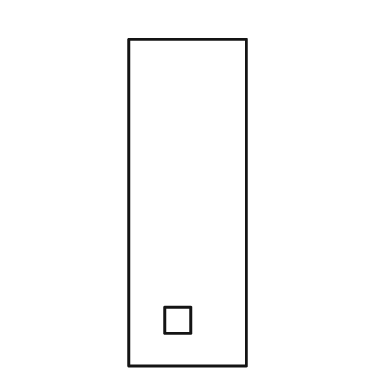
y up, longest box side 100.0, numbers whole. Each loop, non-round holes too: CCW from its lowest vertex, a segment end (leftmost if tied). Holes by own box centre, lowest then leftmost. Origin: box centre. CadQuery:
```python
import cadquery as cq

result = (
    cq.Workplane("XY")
    .moveTo(-18.0, -50.0)
    .lineTo(18.0, -50.0)
    .lineTo(18.0, 50.0)
    .lineTo(-18.0, 50.0)
    .close()
    .moveTo(-7.0, -40.0)
    .lineTo(1.0, -40.0)
    .lineTo(1.0, -32.0)
    .lineTo(-7.0, -32.0)
    .close()
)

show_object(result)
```